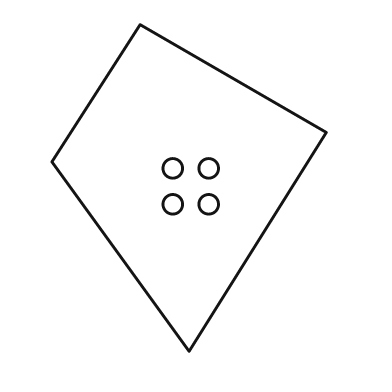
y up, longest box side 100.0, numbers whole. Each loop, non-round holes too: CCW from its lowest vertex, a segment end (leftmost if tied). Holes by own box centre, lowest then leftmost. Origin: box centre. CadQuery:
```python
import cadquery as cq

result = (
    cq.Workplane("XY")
    .moveTo(0.0, -50.0)
    .lineTo(42.0, 17.0)
    .lineTo(-15.0, 50.0)
    .lineTo(-42.0, 8.0)
    .close()
    .moveTo(-5.0, -5.0)
    .circle(3.0)
    .moveTo(6.0, -5.0)
    .circle(3.0)
    .moveTo(-5.0, 6.0)
    .circle(3.0)
    .moveTo(6.0, 6.0)
    .circle(3.0)
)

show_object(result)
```